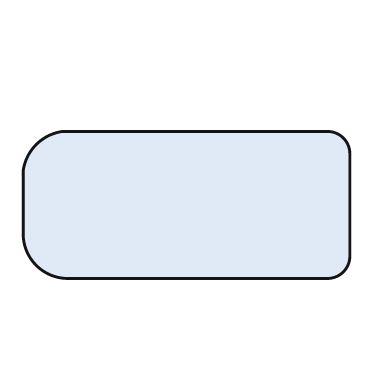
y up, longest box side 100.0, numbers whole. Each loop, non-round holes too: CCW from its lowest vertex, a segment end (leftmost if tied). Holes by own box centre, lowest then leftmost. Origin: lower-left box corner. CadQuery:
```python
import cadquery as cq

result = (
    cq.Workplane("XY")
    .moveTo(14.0, 0.0)
    .lineTo(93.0, 0.0)
    .threePointArc((98.0, 2.0), (100.0, 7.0))
    .lineTo(100.0, 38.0)
    .threePointArc((98.0, 43.0), (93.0, 45.0))
    .lineTo(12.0, 45.0)
    .threePointArc((4.0, 41.0), (0.0, 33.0))
    .lineTo(0.0, 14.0)
    .threePointArc((4.0, 4.0), (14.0, 0.0))
    .close()
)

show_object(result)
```